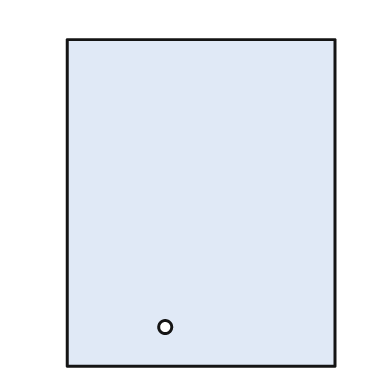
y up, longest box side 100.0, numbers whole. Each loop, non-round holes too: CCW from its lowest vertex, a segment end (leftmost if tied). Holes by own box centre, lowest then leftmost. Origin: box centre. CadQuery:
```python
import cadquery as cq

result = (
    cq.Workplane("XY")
    .moveTo(-41.0, -50.0)
    .lineTo(41.0, -50.0)
    .lineTo(41.0, 50.0)
    .lineTo(-41.0, 50.0)
    .close()
    .moveTo(-11.0, -38.0)
    .circle(2.0)
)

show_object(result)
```